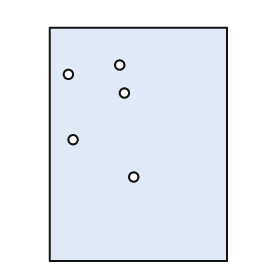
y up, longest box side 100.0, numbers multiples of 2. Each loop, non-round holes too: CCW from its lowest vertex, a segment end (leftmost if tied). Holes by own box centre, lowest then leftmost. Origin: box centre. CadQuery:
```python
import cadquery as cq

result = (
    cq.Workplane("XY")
    .moveTo(-38.0, -50.0)
    .lineTo(38.0, -50.0)
    .lineTo(38.0, 50.0)
    .lineTo(-38.0, 50.0)
    .close()
    .moveTo(-2.0, -14.0)
    .circle(2.0)
    .moveTo(-28.0, 2.0)
    .circle(2.0)
    .moveTo(-6.0, 22.0)
    .circle(2.0)
    .moveTo(-30.0, 30.0)
    .circle(2.0)
    .moveTo(-8.0, 34.0)
    .circle(2.0)
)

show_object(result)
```